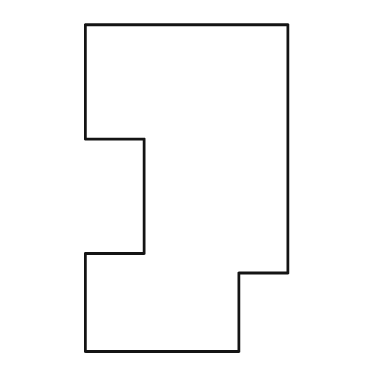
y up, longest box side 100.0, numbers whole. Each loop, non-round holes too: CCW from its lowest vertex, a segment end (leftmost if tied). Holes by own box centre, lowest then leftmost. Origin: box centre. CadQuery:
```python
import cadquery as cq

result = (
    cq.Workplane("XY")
    .moveTo(-31.0, -50.0)
    .lineTo(16.0, -50.0)
    .lineTo(16.0, -26.0)
    .lineTo(31.0, -26.0)
    .lineTo(31.0, 50.0)
    .lineTo(-31.0, 50.0)
    .lineTo(-31.0, 15.0)
    .lineTo(-13.0, 15.0)
    .lineTo(-13.0, -20.0)
    .lineTo(-31.0, -20.0)
    .close()
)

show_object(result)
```